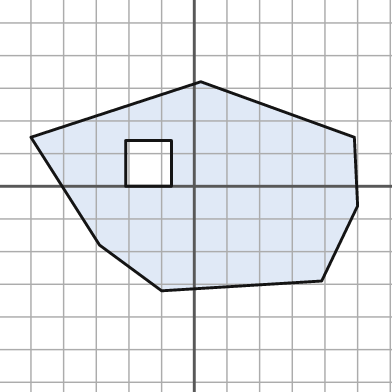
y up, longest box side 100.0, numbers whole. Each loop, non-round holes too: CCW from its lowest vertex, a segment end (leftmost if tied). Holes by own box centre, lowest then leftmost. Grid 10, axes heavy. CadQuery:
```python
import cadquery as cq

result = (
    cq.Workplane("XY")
    .moveTo(-10.0, -32.0)
    .lineTo(39.0, -29.0)
    .lineTo(50.0, -6.0)
    .lineTo(49.0, 15.0)
    .lineTo(2.0, 32.0)
    .lineTo(-50.0, 15.0)
    .lineTo(-29.0, -18.0)
    .close()
    .moveTo(-21.0, 0.0)
    .lineTo(-7.0, 0.0)
    .lineTo(-7.0, 14.0)
    .lineTo(-21.0, 14.0)
    .close()
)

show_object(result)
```